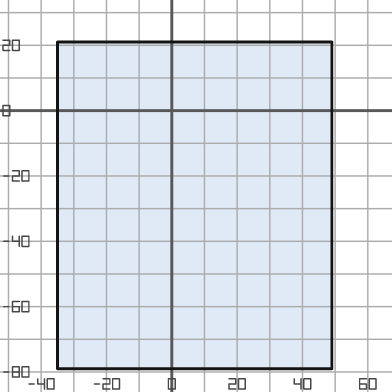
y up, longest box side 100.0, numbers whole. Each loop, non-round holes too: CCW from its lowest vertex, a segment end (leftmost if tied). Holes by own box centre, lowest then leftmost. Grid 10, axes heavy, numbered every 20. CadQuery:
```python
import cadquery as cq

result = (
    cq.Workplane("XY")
    .moveTo(-35.0, -79.0)
    .lineTo(49.0, -79.0)
    .lineTo(49.0, 21.0)
    .lineTo(-35.0, 21.0)
    .close()
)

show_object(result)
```